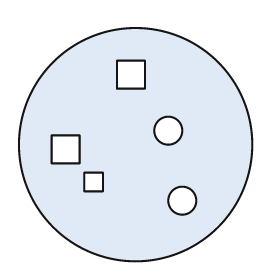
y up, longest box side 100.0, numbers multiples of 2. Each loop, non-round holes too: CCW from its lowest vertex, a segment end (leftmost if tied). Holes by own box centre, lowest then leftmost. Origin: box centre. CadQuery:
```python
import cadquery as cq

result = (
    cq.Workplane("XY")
    .moveTo(0.0, 0.0)
    .circle(50.0)
    .moveTo(20.0, -24.0)
    .circle(6.0)
    .moveTo(-22.0, -20.0)
    .lineTo(-14.0, -20.0)
    .lineTo(-14.0, -12.0)
    .lineTo(-22.0, -12.0)
    .close()
    .moveTo(-36.0, -8.0)
    .lineTo(-24.0, -8.0)
    .lineTo(-24.0, 4.0)
    .lineTo(-36.0, 4.0)
    .close()
    .moveTo(14.0, 6.0)
    .circle(6.0)
    .moveTo(-8.0, 24.0)
    .lineTo(4.0, 24.0)
    .lineTo(4.0, 36.0)
    .lineTo(-8.0, 36.0)
    .close()
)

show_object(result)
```